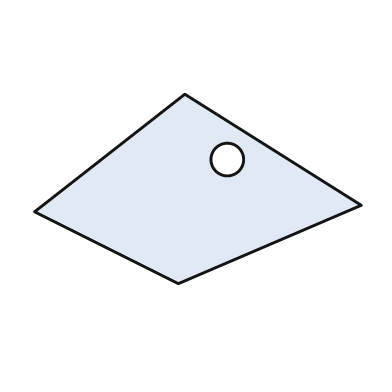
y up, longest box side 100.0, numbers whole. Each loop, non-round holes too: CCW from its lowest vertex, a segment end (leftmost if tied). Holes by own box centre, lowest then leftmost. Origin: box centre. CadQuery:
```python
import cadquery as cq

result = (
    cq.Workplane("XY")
    .moveTo(-6.0, -29.0)
    .lineTo(50.0, -5.0)
    .lineTo(-4.0, 29.0)
    .lineTo(-50.0, -7.0)
    .close()
    .moveTo(9.0, 9.0)
    .circle(5.0)
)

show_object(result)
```